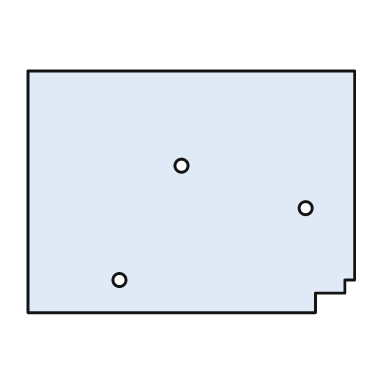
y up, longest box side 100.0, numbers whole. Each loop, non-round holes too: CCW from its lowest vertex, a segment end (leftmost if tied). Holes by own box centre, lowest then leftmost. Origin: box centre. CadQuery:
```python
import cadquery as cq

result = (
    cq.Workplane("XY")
    .moveTo(-50.0, -37.0)
    .lineTo(38.0, -37.0)
    .lineTo(38.0, -31.0)
    .lineTo(47.0, -31.0)
    .lineTo(47.0, -27.0)
    .lineTo(50.0, -27.0)
    .lineTo(50.0, 37.0)
    .lineTo(-50.0, 37.0)
    .close()
    .moveTo(-22.0, -27.0)
    .circle(2.0)
    .moveTo(35.0, -5.0)
    .circle(2.0)
    .moveTo(-3.0, 8.0)
    .circle(2.0)
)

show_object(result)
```